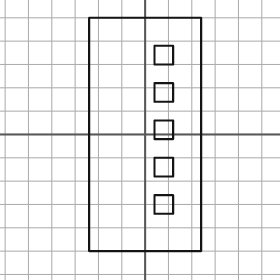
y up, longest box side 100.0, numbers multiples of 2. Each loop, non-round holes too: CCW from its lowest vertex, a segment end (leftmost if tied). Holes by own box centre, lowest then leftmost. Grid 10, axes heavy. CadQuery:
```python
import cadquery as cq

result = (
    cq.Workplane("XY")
    .moveTo(-24.0, -50.0)
    .lineTo(24.0, -50.0)
    .lineTo(24.0, 50.0)
    .lineTo(-24.0, 50.0)
    .close()
    .moveTo(4.0, -34.0)
    .lineTo(12.0, -34.0)
    .lineTo(12.0, -26.0)
    .lineTo(4.0, -26.0)
    .close()
    .moveTo(4.0, -18.0)
    .lineTo(12.0, -18.0)
    .lineTo(12.0, -10.0)
    .lineTo(4.0, -10.0)
    .close()
    .moveTo(4.0, -2.0)
    .lineTo(12.0, -2.0)
    .lineTo(12.0, 6.0)
    .lineTo(4.0, 6.0)
    .close()
    .moveTo(4.0, 14.0)
    .lineTo(12.0, 14.0)
    .lineTo(12.0, 22.0)
    .lineTo(4.0, 22.0)
    .close()
    .moveTo(4.0, 30.0)
    .lineTo(12.0, 30.0)
    .lineTo(12.0, 38.0)
    .lineTo(4.0, 38.0)
    .close()
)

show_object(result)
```